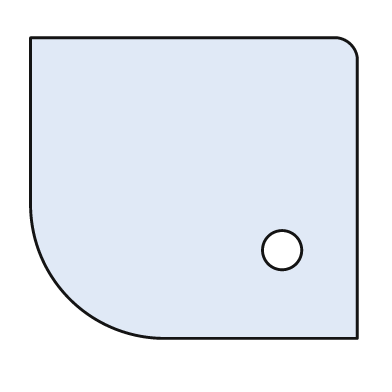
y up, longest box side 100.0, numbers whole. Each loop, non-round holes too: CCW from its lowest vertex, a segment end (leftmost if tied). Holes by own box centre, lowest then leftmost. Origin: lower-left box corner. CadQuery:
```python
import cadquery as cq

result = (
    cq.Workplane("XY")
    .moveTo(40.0, 0.0)
    .lineTo(100.0, 0.0)
    .lineTo(100.0, 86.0)
    .threePointArc((98.0, 90.0), (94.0, 92.0))
    .lineTo(0.0, 92.0)
    .lineTo(0.0, 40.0)
    .threePointArc((12.0, 12.0), (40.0, 0.0))
    .close()
    .moveTo(77.0, 27.0)
    .circle(6.0)
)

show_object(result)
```